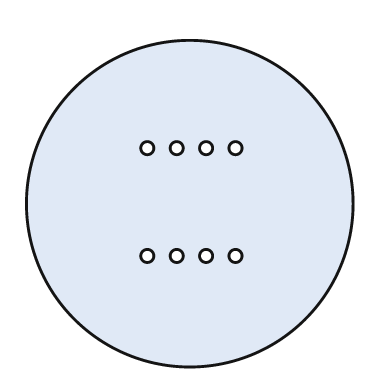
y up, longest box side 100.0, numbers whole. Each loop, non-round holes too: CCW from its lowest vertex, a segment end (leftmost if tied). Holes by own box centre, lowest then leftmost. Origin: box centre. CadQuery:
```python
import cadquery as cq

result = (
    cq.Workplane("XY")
    .moveTo(0.0, 0.0)
    .circle(50.0)
    .moveTo(-13.0, -16.0)
    .circle(2.0)
    .moveTo(-4.0, -16.0)
    .circle(2.0)
    .moveTo(5.0, -16.0)
    .circle(2.0)
    .moveTo(14.0, -16.0)
    .circle(2.0)
    .moveTo(-13.0, 17.0)
    .circle(2.0)
    .moveTo(-4.0, 17.0)
    .circle(2.0)
    .moveTo(5.0, 17.0)
    .circle(2.0)
    .moveTo(14.0, 17.0)
    .circle(2.0)
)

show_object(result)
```